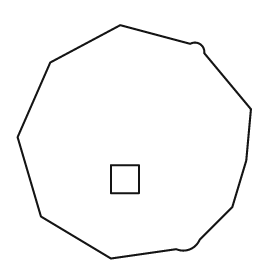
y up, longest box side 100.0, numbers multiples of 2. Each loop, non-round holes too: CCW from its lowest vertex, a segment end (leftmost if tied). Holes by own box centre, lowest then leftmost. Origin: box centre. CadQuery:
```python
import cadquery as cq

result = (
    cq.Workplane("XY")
    .moveTo(-10.0, -50.0)
    .lineTo(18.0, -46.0)
    .threePointArc((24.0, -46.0), (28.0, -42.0))
    .lineTo(42.0, -28.0)
    .lineTo(48.0, -8.0)
    .lineTo(50.0, 14.0)
    .lineTo(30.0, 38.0)
    .threePointArc((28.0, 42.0), (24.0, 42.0))
    .lineTo(-6.0, 50.0)
    .lineTo(-36.0, 34.0)
    .lineTo(-50.0, 2.0)
    .lineTo(-40.0, -32.0)
    .close()
    .moveTo(-10.0, -22.0)
    .lineTo(2.0, -22.0)
    .lineTo(2.0, -10.0)
    .lineTo(-10.0, -10.0)
    .close()
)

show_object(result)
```